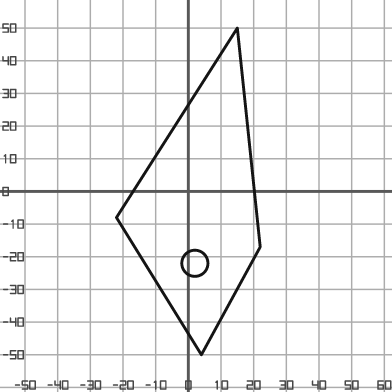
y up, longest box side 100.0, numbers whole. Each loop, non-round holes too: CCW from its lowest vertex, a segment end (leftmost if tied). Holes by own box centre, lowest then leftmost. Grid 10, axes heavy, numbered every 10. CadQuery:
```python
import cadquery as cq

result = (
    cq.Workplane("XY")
    .moveTo(4.0, -50.0)
    .lineTo(22.0, -17.0)
    .lineTo(15.0, 50.0)
    .lineTo(-22.0, -8.0)
    .close()
    .moveTo(2.0, -22.0)
    .circle(4.0)
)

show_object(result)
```